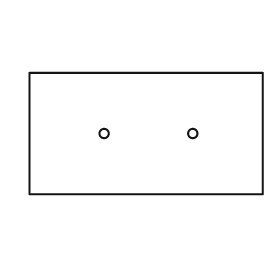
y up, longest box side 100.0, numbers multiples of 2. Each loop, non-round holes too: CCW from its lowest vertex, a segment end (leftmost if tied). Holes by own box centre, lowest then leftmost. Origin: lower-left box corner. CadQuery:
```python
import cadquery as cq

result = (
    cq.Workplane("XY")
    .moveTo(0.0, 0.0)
    .lineTo(100.0, 0.0)
    .lineTo(100.0, 52.0)
    .lineTo(0.0, 52.0)
    .close()
    .moveTo(32.0, 26.0)
    .circle(2.0)
    .moveTo(70.0, 26.0)
    .circle(2.0)
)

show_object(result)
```